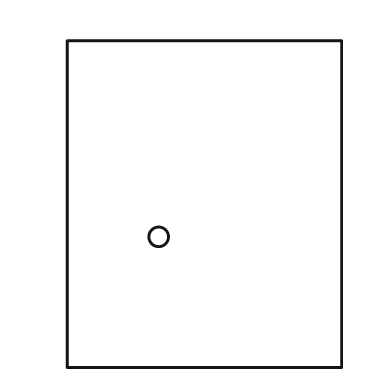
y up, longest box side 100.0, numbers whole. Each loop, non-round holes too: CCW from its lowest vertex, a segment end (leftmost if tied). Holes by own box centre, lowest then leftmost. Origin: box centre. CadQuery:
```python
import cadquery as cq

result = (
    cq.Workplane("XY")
    .moveTo(-42.0, -50.0)
    .lineTo(42.0, -50.0)
    .lineTo(42.0, 50.0)
    .lineTo(-42.0, 50.0)
    .close()
    .moveTo(-14.0, -10.0)
    .circle(3.0)
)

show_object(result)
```